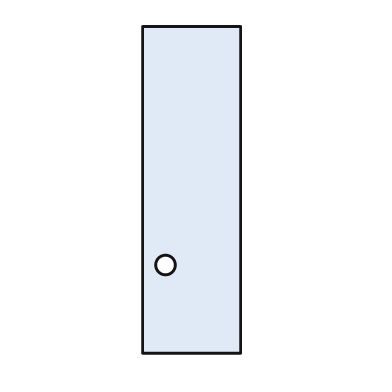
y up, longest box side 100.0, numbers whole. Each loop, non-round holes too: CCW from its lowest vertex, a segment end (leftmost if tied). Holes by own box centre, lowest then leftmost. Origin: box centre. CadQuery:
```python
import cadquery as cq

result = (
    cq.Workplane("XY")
    .moveTo(-15.0, -50.0)
    .lineTo(15.0, -50.0)
    .lineTo(15.0, 50.0)
    .lineTo(-15.0, 50.0)
    .close()
    .moveTo(-8.0, -23.0)
    .circle(3.0)
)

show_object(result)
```